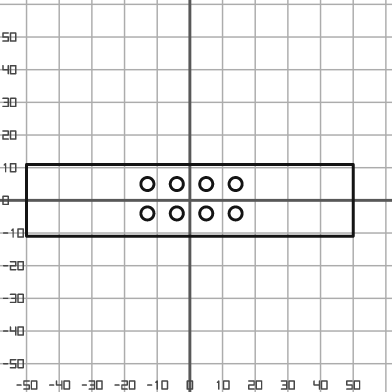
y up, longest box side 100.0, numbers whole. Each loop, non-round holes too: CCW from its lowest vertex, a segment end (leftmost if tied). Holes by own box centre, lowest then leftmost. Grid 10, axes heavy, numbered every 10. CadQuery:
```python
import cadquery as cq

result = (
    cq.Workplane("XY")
    .moveTo(-50.0, -11.0)
    .lineTo(50.0, -11.0)
    .lineTo(50.0, 11.0)
    .lineTo(-50.0, 11.0)
    .close()
    .moveTo(-13.0, -4.0)
    .circle(2.0)
    .moveTo(-4.0, -4.0)
    .circle(2.0)
    .moveTo(5.0, -4.0)
    .circle(2.0)
    .moveTo(14.0, -4.0)
    .circle(2.0)
    .moveTo(-13.0, 5.0)
    .circle(2.0)
    .moveTo(-4.0, 5.0)
    .circle(2.0)
    .moveTo(5.0, 5.0)
    .circle(2.0)
    .moveTo(14.0, 5.0)
    .circle(2.0)
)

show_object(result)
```